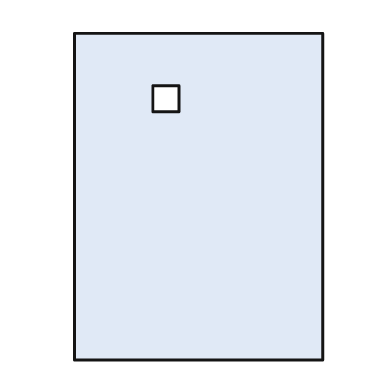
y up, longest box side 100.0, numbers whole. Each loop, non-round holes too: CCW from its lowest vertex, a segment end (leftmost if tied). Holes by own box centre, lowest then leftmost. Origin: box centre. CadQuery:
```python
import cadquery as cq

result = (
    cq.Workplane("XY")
    .moveTo(-38.0, -50.0)
    .lineTo(38.0, -50.0)
    .lineTo(38.0, 50.0)
    .lineTo(-38.0, 50.0)
    .close()
    .moveTo(-14.0, 26.0)
    .lineTo(-6.0, 26.0)
    .lineTo(-6.0, 34.0)
    .lineTo(-14.0, 34.0)
    .close()
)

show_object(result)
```